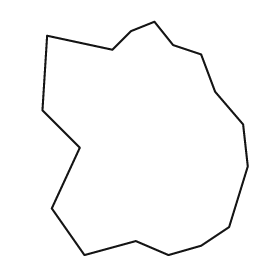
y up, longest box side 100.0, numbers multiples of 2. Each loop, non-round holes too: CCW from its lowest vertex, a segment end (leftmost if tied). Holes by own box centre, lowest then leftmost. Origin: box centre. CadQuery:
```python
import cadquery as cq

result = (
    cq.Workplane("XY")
    .moveTo(-26.0, -50.0)
    .lineTo(-4.0, -44.0)
    .lineTo(10.0, -50.0)
    .lineTo(24.0, -46.0)
    .lineTo(36.0, -38.0)
    .lineTo(44.0, -12.0)
    .lineTo(42.0, 6.0)
    .lineTo(30.0, 20.0)
    .lineTo(24.0, 36.0)
    .lineTo(12.0, 40.0)
    .lineTo(4.0, 50.0)
    .lineTo(-6.0, 46.0)
    .lineTo(-14.0, 38.0)
    .lineTo(-42.0, 44.0)
    .lineTo(-44.0, 12.0)
    .lineTo(-28.0, -4.0)
    .lineTo(-40.0, -30.0)
    .close()
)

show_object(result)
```